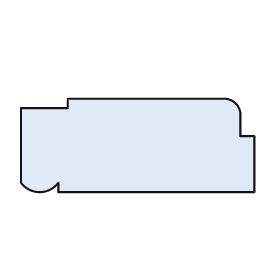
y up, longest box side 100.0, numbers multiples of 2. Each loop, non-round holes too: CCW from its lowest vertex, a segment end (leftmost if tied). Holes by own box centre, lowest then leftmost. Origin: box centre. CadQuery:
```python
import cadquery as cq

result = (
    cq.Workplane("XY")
    .moveTo(-34.0, -20.0)
    .lineTo(50.0, -20.0)
    .lineTo(50.0, 4.0)
    .lineTo(44.0, 4.0)
    .lineTo(44.0, 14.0)
    .threePointArc((42.0, 18.0), (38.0, 20.0))
    .lineTo(-30.0, 20.0)
    .lineTo(-30.0, 16.0)
    .lineTo(-50.0, 16.0)
    .lineTo(-50.0, -16.0)
    .threePointArc((-42.0, -20.0), (-34.0, -16.0))
    .close()
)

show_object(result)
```